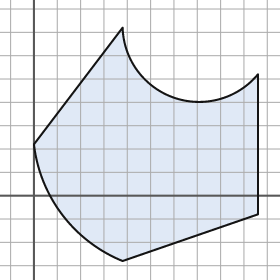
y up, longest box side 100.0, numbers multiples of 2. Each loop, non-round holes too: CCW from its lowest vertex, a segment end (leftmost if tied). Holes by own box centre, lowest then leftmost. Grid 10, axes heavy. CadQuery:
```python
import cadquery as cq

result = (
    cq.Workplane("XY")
    .moveTo(38.0, -28.0)
    .lineTo(96.0, -8.0)
    .lineTo(96.0, 52.0)
    .threePointArc((60.0, 42.0), (38.0, 72.0))
    .lineTo(0.0, 22.0)
    .threePointArc((12.0, -8.0), (38.0, -28.0))
    .close()
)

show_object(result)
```